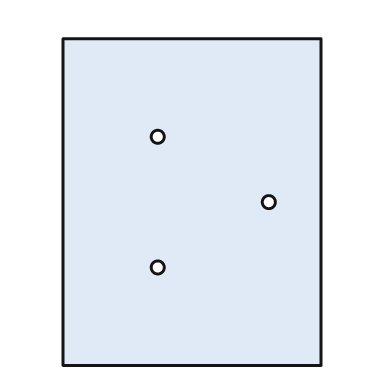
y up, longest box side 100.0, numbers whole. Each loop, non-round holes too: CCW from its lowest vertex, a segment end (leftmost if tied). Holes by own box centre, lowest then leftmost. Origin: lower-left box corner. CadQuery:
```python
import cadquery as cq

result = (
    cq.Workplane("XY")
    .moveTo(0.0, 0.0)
    .lineTo(79.0, 0.0)
    .lineTo(79.0, 100.0)
    .lineTo(0.0, 100.0)
    .close()
    .moveTo(29.0, 30.0)
    .circle(2.0)
    .moveTo(63.0, 50.0)
    .circle(2.0)
    .moveTo(29.0, 70.0)
    .circle(2.0)
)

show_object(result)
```